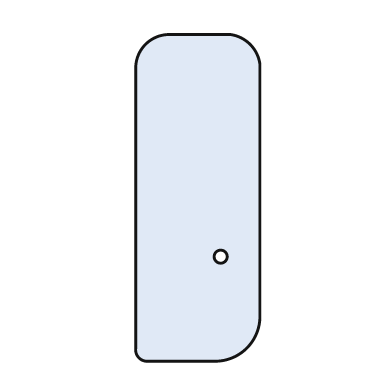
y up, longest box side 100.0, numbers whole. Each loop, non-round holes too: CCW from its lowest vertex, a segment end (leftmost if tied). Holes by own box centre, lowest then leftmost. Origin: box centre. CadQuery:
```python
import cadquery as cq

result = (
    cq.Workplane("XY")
    .moveTo(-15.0, -50.0)
    .lineTo(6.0, -50.0)
    .threePointArc((15.0, -46.0), (19.0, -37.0))
    .lineTo(19.0, 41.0)
    .threePointArc((16.0, 47.0), (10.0, 50.0))
    .lineTo(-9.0, 50.0)
    .threePointArc((-16.0, 47.0), (-19.0, 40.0))
    .lineTo(-19.0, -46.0)
    .threePointArc((-18.0, -49.0), (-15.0, -50.0))
    .close()
    .moveTo(7.0, -18.0)
    .circle(2.0)
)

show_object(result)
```